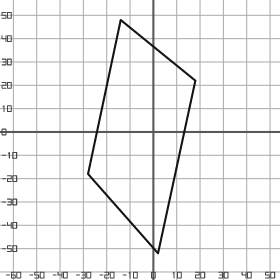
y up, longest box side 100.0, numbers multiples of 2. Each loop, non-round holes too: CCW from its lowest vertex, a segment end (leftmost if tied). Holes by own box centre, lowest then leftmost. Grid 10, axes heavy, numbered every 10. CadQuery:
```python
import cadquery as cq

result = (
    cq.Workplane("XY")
    .moveTo(2.0, -52.0)
    .lineTo(18.0, 22.0)
    .lineTo(-14.0, 48.0)
    .lineTo(-28.0, -18.0)
    .close()
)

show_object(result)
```